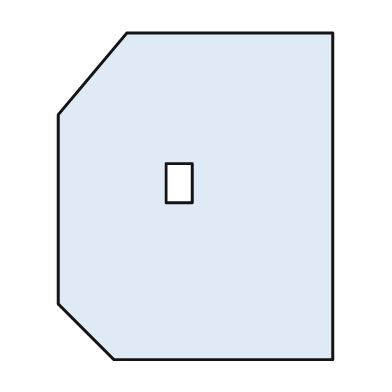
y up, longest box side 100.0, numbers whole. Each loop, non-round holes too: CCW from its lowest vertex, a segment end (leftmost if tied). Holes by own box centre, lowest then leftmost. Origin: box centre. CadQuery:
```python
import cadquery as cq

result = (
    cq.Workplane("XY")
    .moveTo(-25.0, -50.0)
    .lineTo(42.0, -50.0)
    .lineTo(42.0, 50.0)
    .lineTo(-21.0, 50.0)
    .lineTo(-42.0, 25.0)
    .lineTo(-42.0, -33.0)
    .close()
    .moveTo(-9.0, -2.0)
    .lineTo(-1.0, -2.0)
    .lineTo(-1.0, 10.0)
    .lineTo(-9.0, 10.0)
    .close()
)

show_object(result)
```